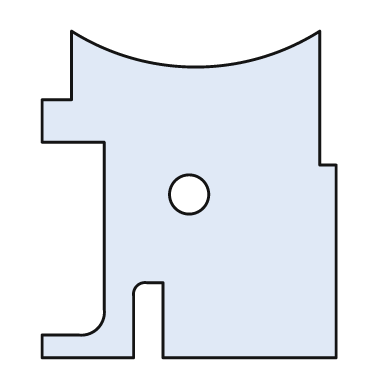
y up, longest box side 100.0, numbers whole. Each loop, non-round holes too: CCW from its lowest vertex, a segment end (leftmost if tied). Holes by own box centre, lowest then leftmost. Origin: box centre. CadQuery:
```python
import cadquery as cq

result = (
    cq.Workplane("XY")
    .moveTo(-45.0, -50.0)
    .lineTo(-17.0, -50.0)
    .lineTo(-17.0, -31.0)
    .threePointArc((-16.0, -28.0), (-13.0, -27.0))
    .lineTo(-8.0, -27.0)
    .lineTo(-8.0, -50.0)
    .lineTo(45.0, -50.0)
    .lineTo(45.0, 9.0)
    .lineTo(40.0, 9.0)
    .lineTo(40.0, 50.0)
    .threePointArc((2.0, 39.0), (-36.0, 50.0))
    .lineTo(-36.0, 29.0)
    .lineTo(-45.0, 29.0)
    .lineTo(-45.0, 16.0)
    .lineTo(-26.0, 16.0)
    .lineTo(-26.0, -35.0)
    .threePointArc((-28.0, -41.0), (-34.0, -43.0))
    .lineTo(-45.0, -43.0)
    .close()
    .moveTo(0.0, 0.0)
    .circle(6.0)
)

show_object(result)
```